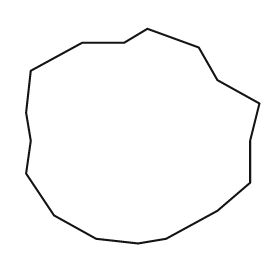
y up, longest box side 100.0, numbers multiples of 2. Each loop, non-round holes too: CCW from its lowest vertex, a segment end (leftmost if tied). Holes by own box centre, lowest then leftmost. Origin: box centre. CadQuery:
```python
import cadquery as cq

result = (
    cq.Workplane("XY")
    .moveTo(-2.0, -46.0)
    .lineTo(10.0, -44.0)
    .lineTo(32.0, -32.0)
    .lineTo(46.0, -20.0)
    .lineTo(46.0, -2.0)
    .lineTo(50.0, 14.0)
    .lineTo(32.0, 24.0)
    .lineTo(24.0, 38.0)
    .lineTo(2.0, 46.0)
    .lineTo(-8.0, 40.0)
    .lineTo(-26.0, 40.0)
    .lineTo(-48.0, 28.0)
    .lineTo(-50.0, 10.0)
    .lineTo(-48.0, -2.0)
    .lineTo(-50.0, -16.0)
    .lineTo(-38.0, -34.0)
    .lineTo(-20.0, -44.0)
    .close()
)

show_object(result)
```